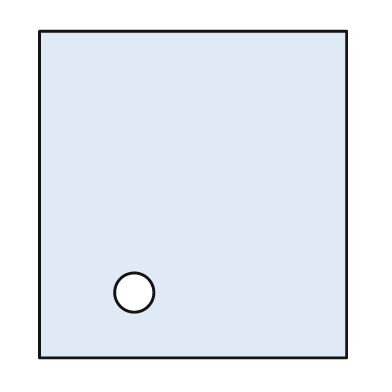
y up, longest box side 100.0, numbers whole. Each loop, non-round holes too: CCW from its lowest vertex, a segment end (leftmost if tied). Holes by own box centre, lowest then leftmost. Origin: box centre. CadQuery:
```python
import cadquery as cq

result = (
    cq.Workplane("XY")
    .moveTo(-47.0, -50.0)
    .lineTo(47.0, -50.0)
    .lineTo(47.0, 50.0)
    .lineTo(-47.0, 50.0)
    .close()
    .moveTo(-18.0, -30.0)
    .circle(6.0)
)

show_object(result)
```